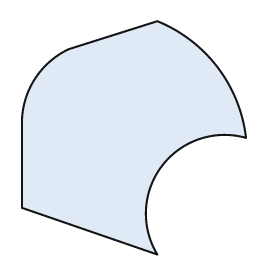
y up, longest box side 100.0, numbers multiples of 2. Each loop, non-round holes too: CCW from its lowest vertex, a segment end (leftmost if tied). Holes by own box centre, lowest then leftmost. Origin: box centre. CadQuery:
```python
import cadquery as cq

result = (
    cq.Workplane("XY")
    .moveTo(10.0, -50.0)
    .threePointArc((12.0, -12.0), (48.0, 0.0))
    .threePointArc((36.0, 30.0), (10.0, 50.0))
    .lineTo(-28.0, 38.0)
    .threePointArc((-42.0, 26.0), (-48.0, 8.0))
    .lineTo(-48.0, -30.0)
    .close()
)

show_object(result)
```